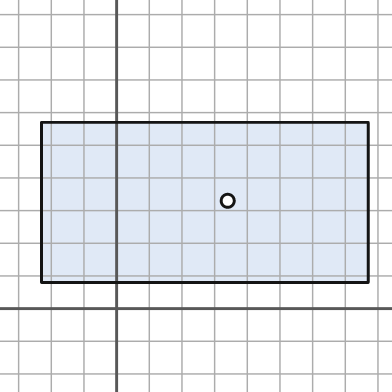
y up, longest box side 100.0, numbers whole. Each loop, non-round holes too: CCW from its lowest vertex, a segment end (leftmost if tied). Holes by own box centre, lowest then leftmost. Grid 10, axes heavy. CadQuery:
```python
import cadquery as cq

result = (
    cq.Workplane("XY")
    .moveTo(-23.0, 8.0)
    .lineTo(77.0, 8.0)
    .lineTo(77.0, 57.0)
    .lineTo(-23.0, 57.0)
    .close()
    .moveTo(34.0, 33.0)
    .circle(2.0)
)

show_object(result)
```